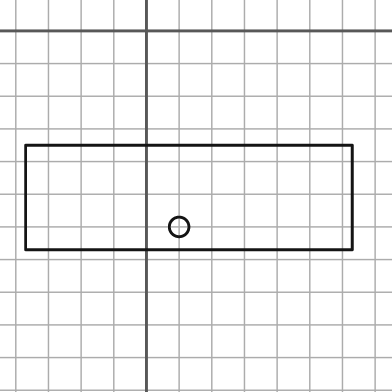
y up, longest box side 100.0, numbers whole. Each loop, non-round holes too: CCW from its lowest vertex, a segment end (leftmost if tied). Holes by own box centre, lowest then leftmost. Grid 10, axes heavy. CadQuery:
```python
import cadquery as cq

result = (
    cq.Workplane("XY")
    .moveTo(-37.0, -67.0)
    .lineTo(63.0, -67.0)
    .lineTo(63.0, -35.0)
    .lineTo(-37.0, -35.0)
    .close()
    .moveTo(10.0, -60.0)
    .circle(3.0)
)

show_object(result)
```